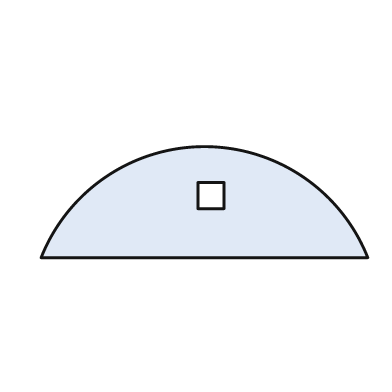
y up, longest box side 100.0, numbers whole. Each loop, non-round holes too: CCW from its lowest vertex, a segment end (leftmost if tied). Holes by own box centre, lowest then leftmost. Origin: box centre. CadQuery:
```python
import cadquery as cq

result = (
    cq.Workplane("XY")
    .moveTo(-50.0, -17.0)
    .lineTo(50.0, -17.0)
    .threePointArc((0.0, 17.0), (-50.0, -17.0))
    .close()
    .moveTo(-2.0, -2.0)
    .lineTo(6.0, -2.0)
    .lineTo(6.0, 6.0)
    .lineTo(-2.0, 6.0)
    .close()
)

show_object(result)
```